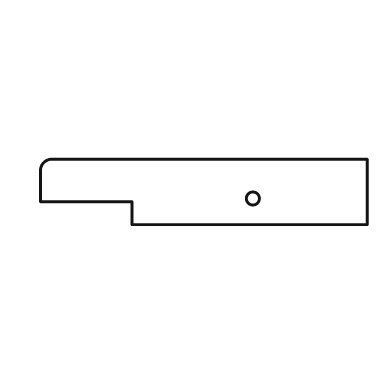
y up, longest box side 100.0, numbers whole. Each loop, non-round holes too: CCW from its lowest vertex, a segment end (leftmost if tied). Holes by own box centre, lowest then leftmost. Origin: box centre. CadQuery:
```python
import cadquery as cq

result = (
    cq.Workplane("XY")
    .moveTo(-22.0, -10.0)
    .lineTo(50.0, -10.0)
    .lineTo(50.0, 10.0)
    .lineTo(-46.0, 10.0)
    .threePointArc((-49.0, 9.0), (-50.0, 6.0))
    .lineTo(-50.0, -3.0)
    .lineTo(-22.0, -3.0)
    .close()
    .moveTo(15.0, -2.0)
    .circle(2.0)
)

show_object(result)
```